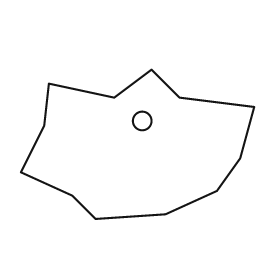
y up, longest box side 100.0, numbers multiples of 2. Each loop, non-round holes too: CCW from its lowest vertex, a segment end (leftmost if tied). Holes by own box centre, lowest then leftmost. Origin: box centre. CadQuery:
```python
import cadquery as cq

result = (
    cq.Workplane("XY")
    .moveTo(-18.0, -32.0)
    .lineTo(12.0, -30.0)
    .lineTo(34.0, -20.0)
    .lineTo(44.0, -6.0)
    .lineTo(50.0, 16.0)
    .lineTo(18.0, 20.0)
    .lineTo(6.0, 32.0)
    .lineTo(-10.0, 20.0)
    .lineTo(-38.0, 26.0)
    .lineTo(-40.0, 8.0)
    .lineTo(-50.0, -12.0)
    .lineTo(-28.0, -22.0)
    .close()
    .moveTo(2.0, 10.0)
    .circle(4.0)
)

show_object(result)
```